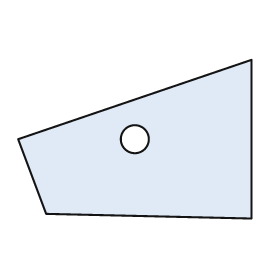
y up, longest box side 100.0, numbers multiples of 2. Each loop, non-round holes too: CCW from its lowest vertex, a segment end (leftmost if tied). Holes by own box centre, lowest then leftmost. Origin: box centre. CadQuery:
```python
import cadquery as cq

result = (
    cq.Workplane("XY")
    .moveTo(50.0, -34.0)
    .lineTo(50.0, 34.0)
    .lineTo(-50.0, 0.0)
    .lineTo(-38.0, -32.0)
    .close()
    .moveTo(0.0, 0.0)
    .circle(6.0)
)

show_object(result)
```